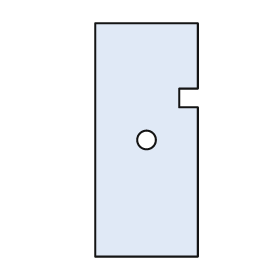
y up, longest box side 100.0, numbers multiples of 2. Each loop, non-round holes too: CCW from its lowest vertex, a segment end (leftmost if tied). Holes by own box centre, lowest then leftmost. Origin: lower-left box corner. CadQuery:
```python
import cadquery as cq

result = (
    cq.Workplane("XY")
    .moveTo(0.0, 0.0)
    .lineTo(44.0, 0.0)
    .lineTo(44.0, 64.0)
    .lineTo(36.0, 64.0)
    .lineTo(36.0, 72.0)
    .lineTo(44.0, 72.0)
    .lineTo(44.0, 100.0)
    .lineTo(0.0, 100.0)
    .close()
    .moveTo(22.0, 50.0)
    .circle(4.0)
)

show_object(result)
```